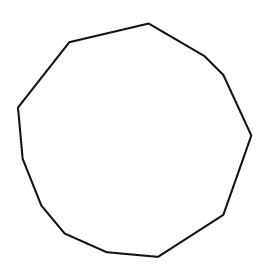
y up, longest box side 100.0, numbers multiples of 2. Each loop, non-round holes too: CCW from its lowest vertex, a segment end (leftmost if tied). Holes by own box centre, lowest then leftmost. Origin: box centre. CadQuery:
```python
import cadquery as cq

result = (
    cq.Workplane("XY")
    .moveTo(10.0, -50.0)
    .lineTo(38.0, -32.0)
    .lineTo(50.0, 2.0)
    .lineTo(38.0, 28.0)
    .lineTo(30.0, 36.0)
    .lineTo(6.0, 50.0)
    .lineTo(-28.0, 42.0)
    .lineTo(-50.0, 14.0)
    .lineTo(-48.0, -8.0)
    .lineTo(-40.0, -28.0)
    .lineTo(-30.0, -40.0)
    .lineTo(-12.0, -48.0)
    .close()
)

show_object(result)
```